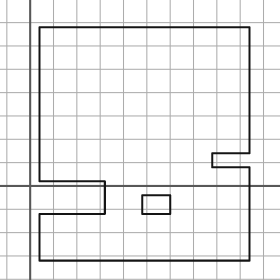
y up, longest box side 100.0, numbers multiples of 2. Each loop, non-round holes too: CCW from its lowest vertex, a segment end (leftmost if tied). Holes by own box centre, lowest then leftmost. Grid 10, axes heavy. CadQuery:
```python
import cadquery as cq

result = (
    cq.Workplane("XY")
    .moveTo(4.0, -32.0)
    .lineTo(94.0, -32.0)
    .lineTo(94.0, 8.0)
    .lineTo(78.0, 8.0)
    .lineTo(78.0, 14.0)
    .lineTo(94.0, 14.0)
    .lineTo(94.0, 68.0)
    .lineTo(4.0, 68.0)
    .lineTo(4.0, 2.0)
    .lineTo(32.0, 2.0)
    .lineTo(32.0, -12.0)
    .lineTo(4.0, -12.0)
    .close()
    .moveTo(48.0, -12.0)
    .lineTo(60.0, -12.0)
    .lineTo(60.0, -4.0)
    .lineTo(48.0, -4.0)
    .close()
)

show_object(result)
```